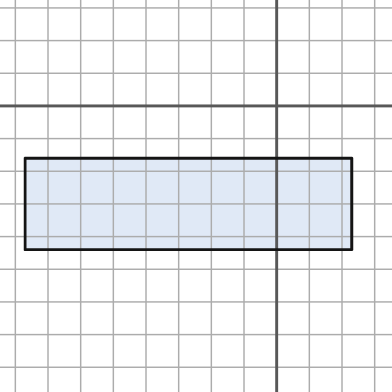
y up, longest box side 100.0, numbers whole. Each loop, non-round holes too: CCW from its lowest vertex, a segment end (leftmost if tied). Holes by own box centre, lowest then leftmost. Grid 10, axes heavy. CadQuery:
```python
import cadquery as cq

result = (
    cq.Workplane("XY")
    .moveTo(-77.0, -44.0)
    .lineTo(23.0, -44.0)
    .lineTo(23.0, -16.0)
    .lineTo(-77.0, -16.0)
    .close()
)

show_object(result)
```